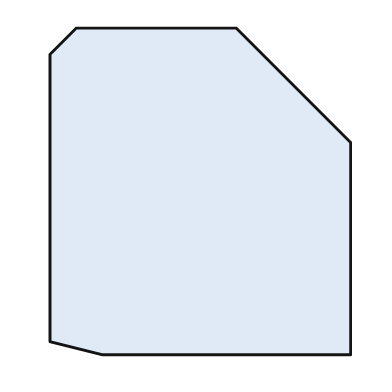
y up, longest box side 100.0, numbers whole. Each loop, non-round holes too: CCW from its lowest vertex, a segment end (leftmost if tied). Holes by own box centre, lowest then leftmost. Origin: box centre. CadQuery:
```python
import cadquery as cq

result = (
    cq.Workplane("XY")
    .moveTo(-30.0, -50.0)
    .lineTo(46.0, -50.0)
    .lineTo(46.0, 15.0)
    .lineTo(11.0, 50.0)
    .lineTo(-38.0, 50.0)
    .lineTo(-46.0, 42.0)
    .lineTo(-46.0, -46.0)
    .close()
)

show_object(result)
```